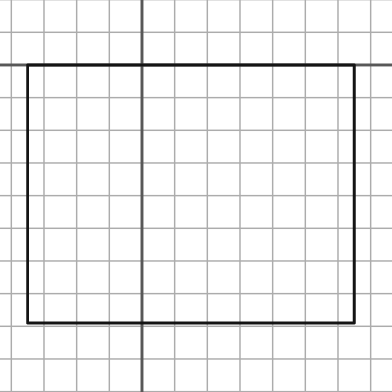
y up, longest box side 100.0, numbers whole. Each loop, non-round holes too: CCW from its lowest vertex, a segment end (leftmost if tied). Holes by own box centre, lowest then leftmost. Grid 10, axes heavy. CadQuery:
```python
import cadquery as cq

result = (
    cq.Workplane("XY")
    .moveTo(-35.0, -79.0)
    .lineTo(65.0, -79.0)
    .lineTo(65.0, 0.0)
    .lineTo(-35.0, 0.0)
    .close()
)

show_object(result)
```